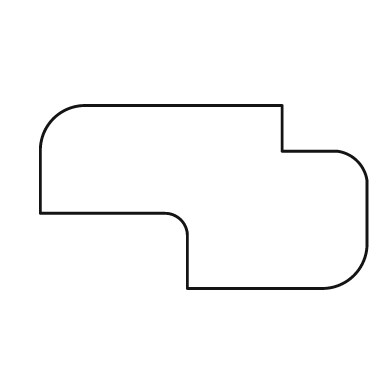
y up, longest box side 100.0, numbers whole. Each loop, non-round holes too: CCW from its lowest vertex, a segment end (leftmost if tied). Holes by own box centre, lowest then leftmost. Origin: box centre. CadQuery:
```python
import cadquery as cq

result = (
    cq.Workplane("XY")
    .moveTo(-5.0, -28.0)
    .lineTo(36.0, -28.0)
    .threePointArc((46.0, -24.0), (50.0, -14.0))
    .lineTo(50.0, 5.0)
    .threePointArc((47.0, 11.0), (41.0, 14.0))
    .lineTo(24.0, 14.0)
    .lineTo(24.0, 28.0)
    .lineTo(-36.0, 28.0)
    .threePointArc((-46.0, 24.0), (-50.0, 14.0))
    .lineTo(-50.0, -5.0)
    .lineTo(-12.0, -5.0)
    .threePointArc((-7.0, -7.0), (-5.0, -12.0))
    .close()
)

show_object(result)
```